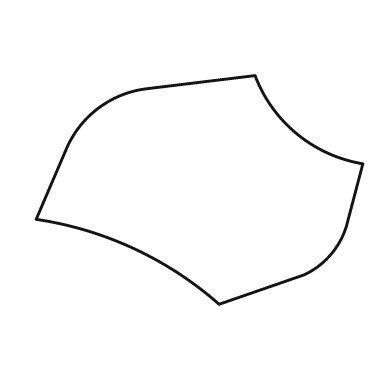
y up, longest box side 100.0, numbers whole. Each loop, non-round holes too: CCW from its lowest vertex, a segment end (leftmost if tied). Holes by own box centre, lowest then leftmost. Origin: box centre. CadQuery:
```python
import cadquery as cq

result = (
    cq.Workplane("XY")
    .moveTo(6.0, -35.0)
    .lineTo(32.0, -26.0)
    .threePointArc((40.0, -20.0), (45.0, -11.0))
    .lineTo(50.0, 8.0)
    .threePointArc((30.0, 17.0), (17.0, 35.0))
    .lineTo(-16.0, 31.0)
    .threePointArc((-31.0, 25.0), (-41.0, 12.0))
    .lineTo(-50.0, -9.0)
    .threePointArc((-20.0, -18.0), (6.0, -35.0))
    .close()
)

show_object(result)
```